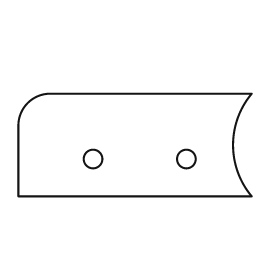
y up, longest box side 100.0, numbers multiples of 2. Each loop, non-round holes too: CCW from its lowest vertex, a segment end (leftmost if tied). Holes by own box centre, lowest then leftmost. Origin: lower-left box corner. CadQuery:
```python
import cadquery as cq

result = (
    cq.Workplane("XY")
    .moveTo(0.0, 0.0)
    .lineTo(100.0, 0.0)
    .threePointArc((92.0, 22.0), (100.0, 44.0))
    .lineTo(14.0, 44.0)
    .threePointArc((4.0, 40.0), (0.0, 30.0))
    .close()
    .moveTo(32.0, 16.0)
    .circle(4.0)
    .moveTo(72.0, 16.0)
    .circle(4.0)
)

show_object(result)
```